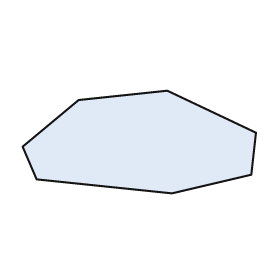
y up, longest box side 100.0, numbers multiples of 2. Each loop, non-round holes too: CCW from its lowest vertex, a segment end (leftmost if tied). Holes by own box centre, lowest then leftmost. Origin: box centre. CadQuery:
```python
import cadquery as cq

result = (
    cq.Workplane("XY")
    .moveTo(14.0, -22.0)
    .lineTo(48.0, -14.0)
    .lineTo(50.0, 4.0)
    .lineTo(12.0, 22.0)
    .lineTo(-26.0, 18.0)
    .lineTo(-50.0, -2.0)
    .lineTo(-44.0, -16.0)
    .close()
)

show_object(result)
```